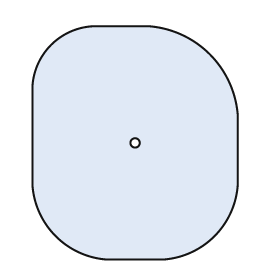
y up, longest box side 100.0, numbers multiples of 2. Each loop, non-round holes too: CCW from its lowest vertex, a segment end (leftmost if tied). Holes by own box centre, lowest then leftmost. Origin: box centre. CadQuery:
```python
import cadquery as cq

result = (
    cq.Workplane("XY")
    .moveTo(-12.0, -50.0)
    .lineTo(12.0, -50.0)
    .threePointArc((34.0, -40.0), (44.0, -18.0))
    .lineTo(44.0, 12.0)
    .threePointArc((32.0, 38.0), (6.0, 50.0))
    .lineTo(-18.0, 50.0)
    .threePointArc((-36.0, 42.0), (-44.0, 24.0))
    .lineTo(-44.0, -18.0)
    .threePointArc((-34.0, -40.0), (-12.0, -50.0))
    .close()
    .moveTo(0.0, 0.0)
    .circle(2.0)
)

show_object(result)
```